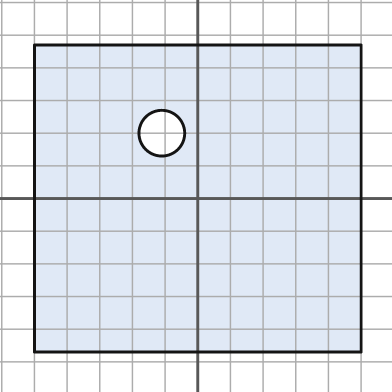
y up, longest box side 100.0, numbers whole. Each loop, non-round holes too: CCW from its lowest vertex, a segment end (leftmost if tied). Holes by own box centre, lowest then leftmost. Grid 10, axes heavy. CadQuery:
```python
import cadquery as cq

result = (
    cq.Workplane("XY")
    .moveTo(-50.0, -47.0)
    .lineTo(50.0, -47.0)
    .lineTo(50.0, 47.0)
    .lineTo(-50.0, 47.0)
    .close()
    .moveTo(-11.0, 20.0)
    .circle(7.0)
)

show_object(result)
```